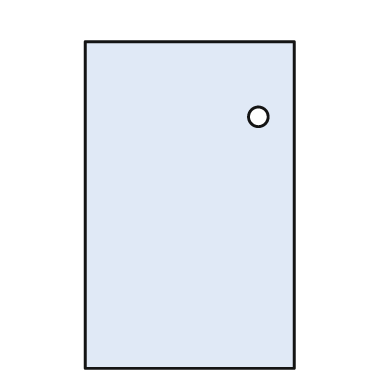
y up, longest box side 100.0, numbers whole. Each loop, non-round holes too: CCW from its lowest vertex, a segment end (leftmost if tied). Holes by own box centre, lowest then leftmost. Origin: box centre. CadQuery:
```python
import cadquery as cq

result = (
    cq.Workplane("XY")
    .moveTo(-32.0, -50.0)
    .lineTo(32.0, -50.0)
    .lineTo(32.0, 50.0)
    .lineTo(-32.0, 50.0)
    .close()
    .moveTo(21.0, 27.0)
    .circle(3.0)
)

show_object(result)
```